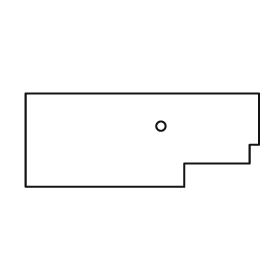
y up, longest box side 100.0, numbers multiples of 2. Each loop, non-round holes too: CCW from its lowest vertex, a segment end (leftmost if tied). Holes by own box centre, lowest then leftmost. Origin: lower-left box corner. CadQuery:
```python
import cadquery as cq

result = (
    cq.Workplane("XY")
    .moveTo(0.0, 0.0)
    .lineTo(68.0, 0.0)
    .lineTo(68.0, 10.0)
    .lineTo(96.0, 10.0)
    .lineTo(96.0, 18.0)
    .lineTo(100.0, 18.0)
    .lineTo(100.0, 40.0)
    .lineTo(0.0, 40.0)
    .close()
    .moveTo(58.0, 26.0)
    .circle(2.0)
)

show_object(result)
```